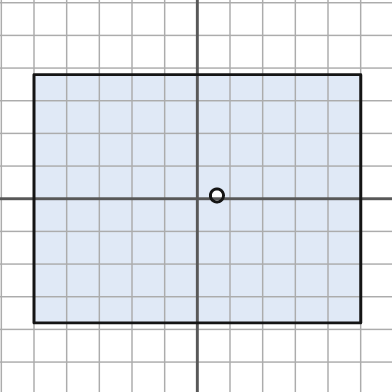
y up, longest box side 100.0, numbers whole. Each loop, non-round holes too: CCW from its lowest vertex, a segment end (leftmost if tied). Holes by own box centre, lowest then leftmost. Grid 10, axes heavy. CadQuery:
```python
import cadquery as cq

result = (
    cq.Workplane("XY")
    .moveTo(-50.0, -38.0)
    .lineTo(50.0, -38.0)
    .lineTo(50.0, 38.0)
    .lineTo(-50.0, 38.0)
    .close()
    .moveTo(6.0, 1.0)
    .circle(2.0)
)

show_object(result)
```